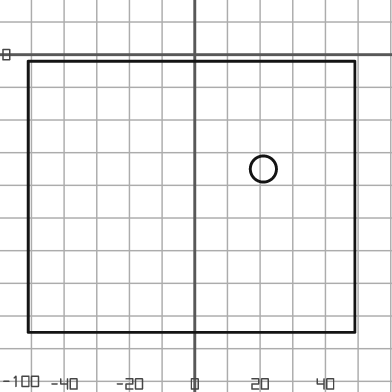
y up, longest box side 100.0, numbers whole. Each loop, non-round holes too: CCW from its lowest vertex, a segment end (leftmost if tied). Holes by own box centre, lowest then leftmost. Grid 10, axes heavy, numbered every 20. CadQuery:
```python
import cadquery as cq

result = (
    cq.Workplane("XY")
    .moveTo(-51.0, -85.0)
    .lineTo(49.0, -85.0)
    .lineTo(49.0, -2.0)
    .lineTo(-51.0, -2.0)
    .close()
    .moveTo(21.0, -35.0)
    .circle(4.0)
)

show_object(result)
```